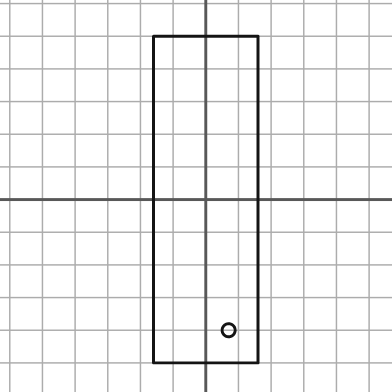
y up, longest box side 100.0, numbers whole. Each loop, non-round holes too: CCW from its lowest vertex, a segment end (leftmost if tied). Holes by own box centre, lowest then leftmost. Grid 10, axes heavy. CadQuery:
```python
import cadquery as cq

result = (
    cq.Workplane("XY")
    .moveTo(-16.0, -50.0)
    .lineTo(16.0, -50.0)
    .lineTo(16.0, 50.0)
    .lineTo(-16.0, 50.0)
    .close()
    .moveTo(7.0, -40.0)
    .circle(2.0)
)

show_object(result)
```